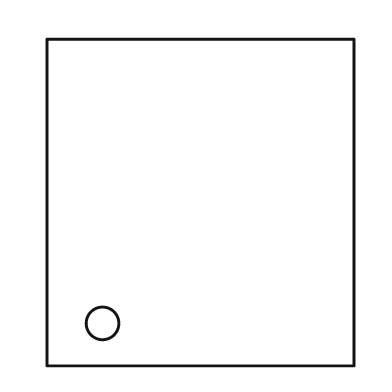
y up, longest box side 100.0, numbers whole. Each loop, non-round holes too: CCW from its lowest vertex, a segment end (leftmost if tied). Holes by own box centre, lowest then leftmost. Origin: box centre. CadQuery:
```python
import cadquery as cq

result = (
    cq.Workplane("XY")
    .moveTo(-47.0, -50.0)
    .lineTo(47.0, -50.0)
    .lineTo(47.0, 50.0)
    .lineTo(-47.0, 50.0)
    .close()
    .moveTo(-30.0, -37.0)
    .circle(5.0)
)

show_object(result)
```